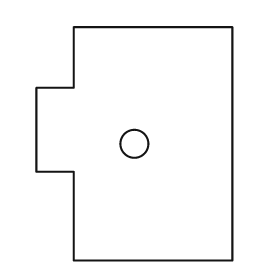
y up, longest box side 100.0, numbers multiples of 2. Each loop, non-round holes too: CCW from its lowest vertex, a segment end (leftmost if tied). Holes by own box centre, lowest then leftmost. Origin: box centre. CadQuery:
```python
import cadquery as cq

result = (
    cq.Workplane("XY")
    .moveTo(-26.0, -50.0)
    .lineTo(42.0, -50.0)
    .lineTo(42.0, 50.0)
    .lineTo(-26.0, 50.0)
    .lineTo(-26.0, 24.0)
    .lineTo(-42.0, 24.0)
    .lineTo(-42.0, -12.0)
    .lineTo(-26.0, -12.0)
    .close()
    .moveTo(0.0, 0.0)
    .circle(6.0)
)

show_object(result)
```